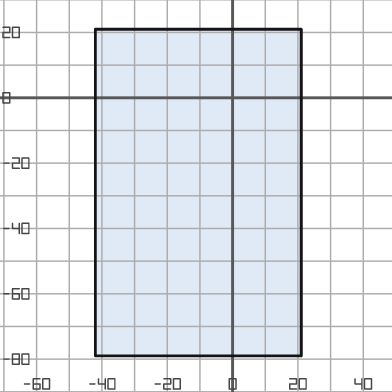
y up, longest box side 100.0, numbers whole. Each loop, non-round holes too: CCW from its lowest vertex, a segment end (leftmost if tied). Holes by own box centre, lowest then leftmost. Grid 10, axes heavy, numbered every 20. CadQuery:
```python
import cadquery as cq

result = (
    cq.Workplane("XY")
    .moveTo(-42.0, -79.0)
    .lineTo(21.0, -79.0)
    .lineTo(21.0, 21.0)
    .lineTo(-42.0, 21.0)
    .close()
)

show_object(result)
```